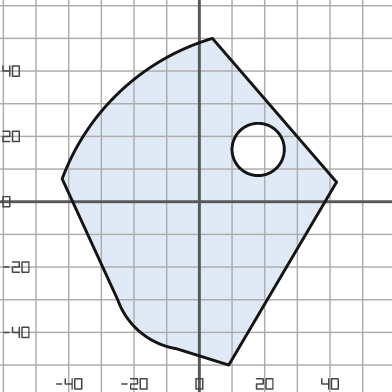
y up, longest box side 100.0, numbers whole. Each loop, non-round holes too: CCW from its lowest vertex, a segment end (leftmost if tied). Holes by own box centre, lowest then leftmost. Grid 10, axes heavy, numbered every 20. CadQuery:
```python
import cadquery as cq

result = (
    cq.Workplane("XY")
    .moveTo(9.0, -50.0)
    .lineTo(42.0, 6.0)
    .lineTo(4.0, 50.0)
    .threePointArc((-24.0, 34.0), (-42.0, 7.0))
    .lineTo(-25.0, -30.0)
    .threePointArc((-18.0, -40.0), (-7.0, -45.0))
    .close()
    .moveTo(18.0, 16.0)
    .circle(8.0)
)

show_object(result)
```